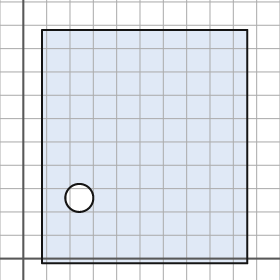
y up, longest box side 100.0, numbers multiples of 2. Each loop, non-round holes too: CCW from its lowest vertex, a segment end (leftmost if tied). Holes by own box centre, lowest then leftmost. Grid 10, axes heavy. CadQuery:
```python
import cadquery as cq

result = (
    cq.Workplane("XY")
    .moveTo(8.0, -2.0)
    .lineTo(96.0, -2.0)
    .lineTo(96.0, 98.0)
    .lineTo(8.0, 98.0)
    .close()
    .moveTo(24.0, 26.0)
    .circle(6.0)
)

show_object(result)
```